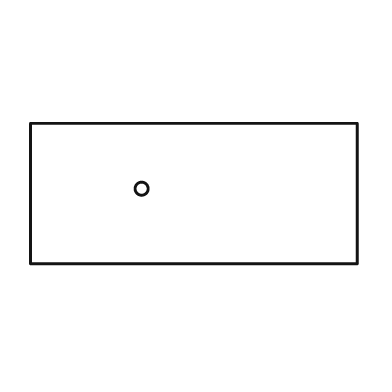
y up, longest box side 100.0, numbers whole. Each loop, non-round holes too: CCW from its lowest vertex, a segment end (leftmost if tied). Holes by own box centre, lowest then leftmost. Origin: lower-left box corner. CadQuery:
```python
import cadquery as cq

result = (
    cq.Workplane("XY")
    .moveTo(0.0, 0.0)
    .lineTo(100.0, 0.0)
    .lineTo(100.0, 43.0)
    .lineTo(0.0, 43.0)
    .close()
    .moveTo(34.0, 23.0)
    .circle(2.0)
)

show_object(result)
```